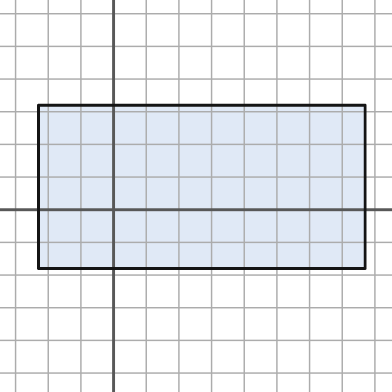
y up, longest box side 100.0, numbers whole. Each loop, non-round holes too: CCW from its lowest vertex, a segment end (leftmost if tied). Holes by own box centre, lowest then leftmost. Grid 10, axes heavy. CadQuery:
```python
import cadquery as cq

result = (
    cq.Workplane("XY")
    .moveTo(-23.0, -18.0)
    .lineTo(77.0, -18.0)
    .lineTo(77.0, 32.0)
    .lineTo(-23.0, 32.0)
    .close()
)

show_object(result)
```